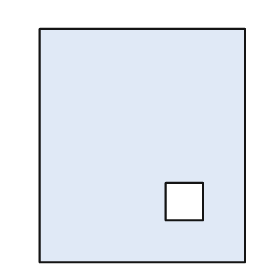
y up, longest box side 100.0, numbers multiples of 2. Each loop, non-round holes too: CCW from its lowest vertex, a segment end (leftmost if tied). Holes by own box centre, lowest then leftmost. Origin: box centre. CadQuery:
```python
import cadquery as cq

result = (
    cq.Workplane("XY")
    .moveTo(-44.0, -50.0)
    .lineTo(44.0, -50.0)
    .lineTo(44.0, 50.0)
    .lineTo(-44.0, 50.0)
    .close()
    .moveTo(10.0, -32.0)
    .lineTo(26.0, -32.0)
    .lineTo(26.0, -16.0)
    .lineTo(10.0, -16.0)
    .close()
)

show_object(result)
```